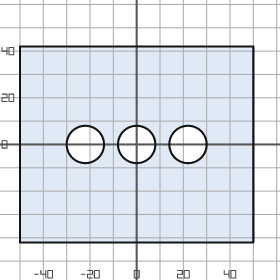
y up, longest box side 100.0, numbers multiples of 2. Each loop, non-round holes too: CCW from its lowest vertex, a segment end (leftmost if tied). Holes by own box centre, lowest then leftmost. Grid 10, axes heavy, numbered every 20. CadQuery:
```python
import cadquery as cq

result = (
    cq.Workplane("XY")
    .moveTo(-50.0, -42.0)
    .lineTo(50.0, -42.0)
    .lineTo(50.0, 42.0)
    .lineTo(-50.0, 42.0)
    .close()
    .moveTo(-22.0, 0.0)
    .circle(8.0)
    .moveTo(0.0, 0.0)
    .circle(8.0)
    .moveTo(22.0, 0.0)
    .circle(8.0)
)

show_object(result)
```